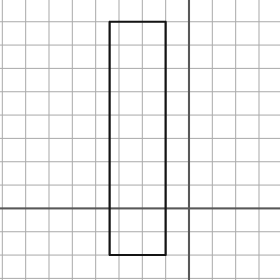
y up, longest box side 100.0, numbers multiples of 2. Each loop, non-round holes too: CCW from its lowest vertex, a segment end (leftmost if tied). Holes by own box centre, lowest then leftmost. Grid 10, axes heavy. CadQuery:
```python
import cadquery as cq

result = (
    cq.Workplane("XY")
    .moveTo(-34.0, -20.0)
    .lineTo(-10.0, -20.0)
    .lineTo(-10.0, 80.0)
    .lineTo(-34.0, 80.0)
    .close()
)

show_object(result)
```